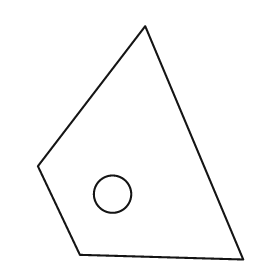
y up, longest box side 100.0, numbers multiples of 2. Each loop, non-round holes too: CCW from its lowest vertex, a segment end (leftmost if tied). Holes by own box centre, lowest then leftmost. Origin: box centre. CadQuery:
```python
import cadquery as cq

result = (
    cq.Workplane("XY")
    .moveTo(44.0, -50.0)
    .lineTo(2.0, 50.0)
    .lineTo(-44.0, -10.0)
    .lineTo(-26.0, -48.0)
    .close()
    .moveTo(-12.0, -22.0)
    .circle(8.0)
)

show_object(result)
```